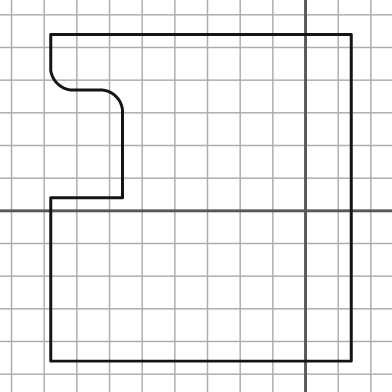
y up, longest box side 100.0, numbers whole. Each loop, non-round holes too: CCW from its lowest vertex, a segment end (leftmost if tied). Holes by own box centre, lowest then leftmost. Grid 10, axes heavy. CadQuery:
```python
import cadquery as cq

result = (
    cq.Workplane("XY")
    .moveTo(-78.0, -46.0)
    .lineTo(14.0, -46.0)
    .lineTo(14.0, 54.0)
    .lineTo(-78.0, 54.0)
    .lineTo(-78.0, 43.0)
    .threePointArc((-76.0, 39.0), (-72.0, 37.0))
    .lineTo(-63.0, 37.0)
    .threePointArc((-58.0, 35.0), (-56.0, 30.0))
    .lineTo(-56.0, 4.0)
    .lineTo(-78.0, 4.0)
    .close()
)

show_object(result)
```